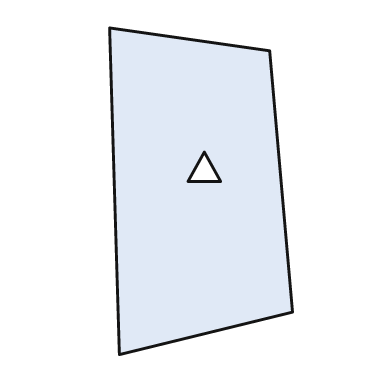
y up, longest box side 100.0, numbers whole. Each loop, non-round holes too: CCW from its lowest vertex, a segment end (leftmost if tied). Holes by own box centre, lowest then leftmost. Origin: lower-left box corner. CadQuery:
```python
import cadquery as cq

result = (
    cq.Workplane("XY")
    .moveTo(3.0, 0.0)
    .lineTo(56.0, 13.0)
    .lineTo(49.0, 93.0)
    .lineTo(0.0, 100.0)
    .close()
    .moveTo(24.0, 53.0)
    .lineTo(34.0, 53.0)
    .lineTo(29.0, 62.0)
    .close()
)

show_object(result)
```